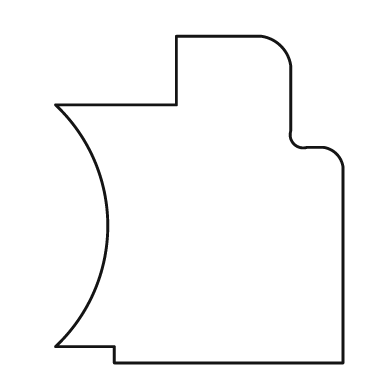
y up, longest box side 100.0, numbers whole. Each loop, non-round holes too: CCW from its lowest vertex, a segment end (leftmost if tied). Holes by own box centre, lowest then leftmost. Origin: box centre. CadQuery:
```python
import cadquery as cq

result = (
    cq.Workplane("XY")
    .moveTo(-26.0, -50.0)
    .lineTo(44.0, -50.0)
    .lineTo(44.0, 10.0)
    .threePointArc((42.0, 14.0), (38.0, 16.0))
    .lineTo(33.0, 16.0)
    .threePointArc((29.0, 17.0), (28.0, 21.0))
    .lineTo(28.0, 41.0)
    .threePointArc((25.0, 47.0), (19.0, 50.0))
    .lineTo(-7.0, 50.0)
    .lineTo(-7.0, 29.0)
    .lineTo(-44.0, 29.0)
    .threePointArc((-28.0, -8.0), (-44.0, -45.0))
    .lineTo(-26.0, -45.0)
    .close()
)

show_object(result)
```